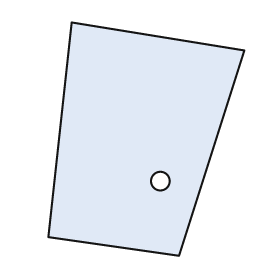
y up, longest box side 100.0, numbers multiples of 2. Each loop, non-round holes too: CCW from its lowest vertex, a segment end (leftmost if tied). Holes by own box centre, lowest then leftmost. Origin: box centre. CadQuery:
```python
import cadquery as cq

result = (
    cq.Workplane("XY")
    .moveTo(14.0, -50.0)
    .lineTo(42.0, 38.0)
    .lineTo(-32.0, 50.0)
    .lineTo(-42.0, -42.0)
    .close()
    .moveTo(6.0, -18.0)
    .circle(4.0)
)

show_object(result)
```